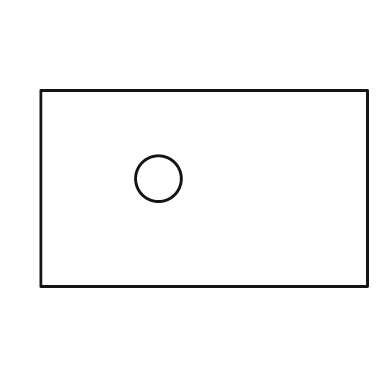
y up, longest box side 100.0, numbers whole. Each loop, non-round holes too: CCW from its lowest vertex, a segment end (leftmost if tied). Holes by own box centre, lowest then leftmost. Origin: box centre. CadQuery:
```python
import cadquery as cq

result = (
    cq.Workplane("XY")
    .moveTo(-50.0, -30.0)
    .lineTo(50.0, -30.0)
    .lineTo(50.0, 30.0)
    .lineTo(-50.0, 30.0)
    .close()
    .moveTo(-14.0, 3.0)
    .circle(7.0)
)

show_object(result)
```